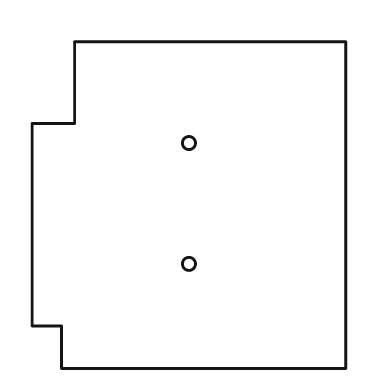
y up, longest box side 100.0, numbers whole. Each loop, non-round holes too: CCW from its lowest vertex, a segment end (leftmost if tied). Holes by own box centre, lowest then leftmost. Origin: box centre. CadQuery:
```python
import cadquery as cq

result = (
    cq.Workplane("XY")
    .moveTo(-39.0, -50.0)
    .lineTo(48.0, -50.0)
    .lineTo(48.0, 50.0)
    .lineTo(-35.0, 50.0)
    .lineTo(-35.0, 25.0)
    .lineTo(-48.0, 25.0)
    .lineTo(-48.0, -37.0)
    .lineTo(-39.0, -37.0)
    .close()
    .moveTo(0.0, -18.0)
    .circle(2.0)
    .moveTo(0.0, 19.0)
    .circle(2.0)
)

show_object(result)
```